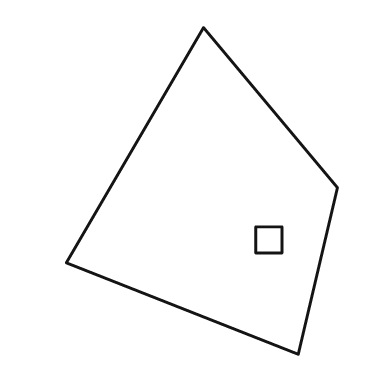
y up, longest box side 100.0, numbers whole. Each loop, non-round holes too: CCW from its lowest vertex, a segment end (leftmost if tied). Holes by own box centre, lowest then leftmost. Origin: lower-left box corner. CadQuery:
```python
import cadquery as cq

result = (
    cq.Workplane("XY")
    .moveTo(71.0, 0.0)
    .lineTo(83.0, 51.0)
    .lineTo(42.0, 100.0)
    .lineTo(0.0, 28.0)
    .close()
    .moveTo(58.0, 31.0)
    .lineTo(66.0, 31.0)
    .lineTo(66.0, 39.0)
    .lineTo(58.0, 39.0)
    .close()
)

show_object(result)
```